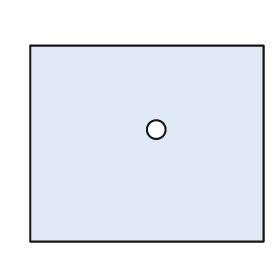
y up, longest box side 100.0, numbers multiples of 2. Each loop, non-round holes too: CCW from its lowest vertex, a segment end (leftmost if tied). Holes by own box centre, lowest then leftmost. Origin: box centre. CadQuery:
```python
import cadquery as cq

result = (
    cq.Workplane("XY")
    .moveTo(-50.0, -42.0)
    .lineTo(50.0, -42.0)
    .lineTo(50.0, 42.0)
    .lineTo(-50.0, 42.0)
    .close()
    .moveTo(4.0, 6.0)
    .circle(4.0)
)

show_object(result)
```